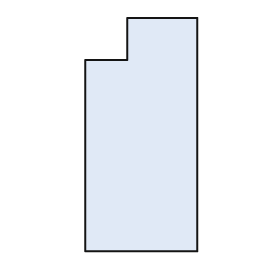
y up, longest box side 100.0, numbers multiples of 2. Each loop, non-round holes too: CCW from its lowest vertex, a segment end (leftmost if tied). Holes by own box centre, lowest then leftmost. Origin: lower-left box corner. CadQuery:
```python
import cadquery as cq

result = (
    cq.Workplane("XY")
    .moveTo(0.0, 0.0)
    .lineTo(48.0, 0.0)
    .lineTo(48.0, 100.0)
    .lineTo(18.0, 100.0)
    .lineTo(18.0, 82.0)
    .lineTo(0.0, 82.0)
    .close()
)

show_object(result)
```